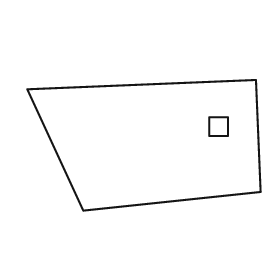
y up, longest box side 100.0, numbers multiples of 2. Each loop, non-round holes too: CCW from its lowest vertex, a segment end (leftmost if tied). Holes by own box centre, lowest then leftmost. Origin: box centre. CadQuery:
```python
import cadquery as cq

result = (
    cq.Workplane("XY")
    .moveTo(-26.0, -28.0)
    .lineTo(50.0, -20.0)
    .lineTo(48.0, 28.0)
    .lineTo(-50.0, 24.0)
    .close()
    .moveTo(28.0, 4.0)
    .lineTo(36.0, 4.0)
    .lineTo(36.0, 12.0)
    .lineTo(28.0, 12.0)
    .close()
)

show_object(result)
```